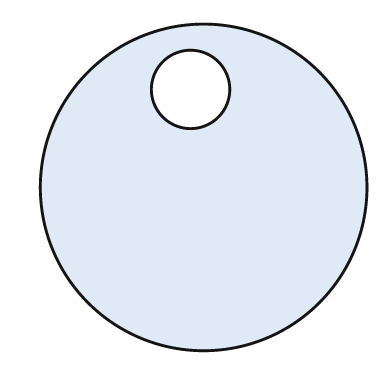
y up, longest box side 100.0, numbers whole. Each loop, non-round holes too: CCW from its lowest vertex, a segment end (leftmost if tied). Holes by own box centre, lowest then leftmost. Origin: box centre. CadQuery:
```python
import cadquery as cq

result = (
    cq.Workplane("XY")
    .moveTo(0.0, 0.0)
    .circle(50.0)
    .moveTo(-4.0, 30.0)
    .circle(12.0)
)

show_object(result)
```